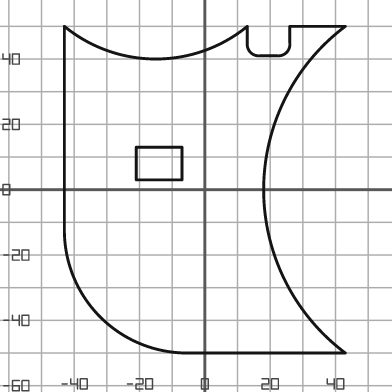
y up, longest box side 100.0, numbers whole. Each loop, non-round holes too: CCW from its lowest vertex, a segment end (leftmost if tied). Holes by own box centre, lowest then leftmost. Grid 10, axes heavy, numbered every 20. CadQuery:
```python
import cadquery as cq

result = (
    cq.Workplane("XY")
    .moveTo(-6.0, -50.0)
    .lineTo(43.0, -50.0)
    .threePointArc((18.0, 0.0), (43.0, 50.0))
    .lineTo(26.0, 50.0)
    .lineTo(26.0, 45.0)
    .threePointArc((25.0, 42.0), (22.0, 41.0))
    .lineTo(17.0, 41.0)
    .threePointArc((14.0, 42.0), (13.0, 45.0))
    .lineTo(13.0, 50.0)
    .threePointArc((-15.0, 40.0), (-43.0, 50.0))
    .lineTo(-43.0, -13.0)
    .threePointArc((-32.0, -39.0), (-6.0, -50.0))
    .close()
    .moveTo(-21.0, 3.0)
    .lineTo(-7.0, 3.0)
    .lineTo(-7.0, 13.0)
    .lineTo(-21.0, 13.0)
    .close()
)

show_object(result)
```